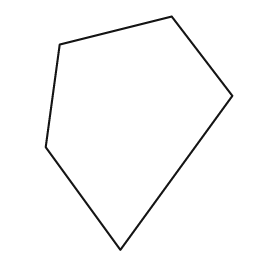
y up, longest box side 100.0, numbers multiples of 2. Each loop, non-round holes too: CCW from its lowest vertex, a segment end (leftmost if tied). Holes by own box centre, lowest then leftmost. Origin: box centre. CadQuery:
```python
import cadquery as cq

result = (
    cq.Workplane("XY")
    .moveTo(-8.0, -50.0)
    .lineTo(40.0, 16.0)
    .lineTo(14.0, 50.0)
    .lineTo(-34.0, 38.0)
    .lineTo(-40.0, -6.0)
    .close()
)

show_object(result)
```